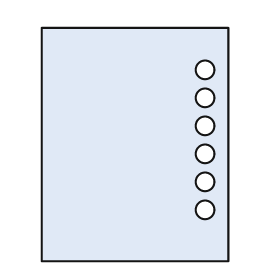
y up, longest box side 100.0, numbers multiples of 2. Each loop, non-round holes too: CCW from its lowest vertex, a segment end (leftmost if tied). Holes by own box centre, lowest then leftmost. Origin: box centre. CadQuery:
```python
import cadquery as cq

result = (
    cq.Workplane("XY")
    .moveTo(-40.0, -50.0)
    .lineTo(40.0, -50.0)
    .lineTo(40.0, 50.0)
    .lineTo(-40.0, 50.0)
    .close()
    .moveTo(30.0, -28.0)
    .circle(4.0)
    .moveTo(30.0, -16.0)
    .circle(4.0)
    .moveTo(30.0, -4.0)
    .circle(4.0)
    .moveTo(30.0, 8.0)
    .circle(4.0)
    .moveTo(30.0, 20.0)
    .circle(4.0)
    .moveTo(30.0, 32.0)
    .circle(4.0)
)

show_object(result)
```